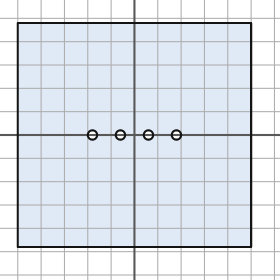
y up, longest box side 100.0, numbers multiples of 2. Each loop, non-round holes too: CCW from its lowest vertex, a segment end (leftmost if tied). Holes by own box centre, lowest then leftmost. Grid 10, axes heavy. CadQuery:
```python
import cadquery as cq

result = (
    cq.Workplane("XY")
    .moveTo(-50.0, -48.0)
    .lineTo(50.0, -48.0)
    .lineTo(50.0, 48.0)
    .lineTo(-50.0, 48.0)
    .close()
    .moveTo(-18.0, 0.0)
    .circle(2.0)
    .moveTo(-6.0, 0.0)
    .circle(2.0)
    .moveTo(6.0, 0.0)
    .circle(2.0)
    .moveTo(18.0, 0.0)
    .circle(2.0)
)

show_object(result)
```